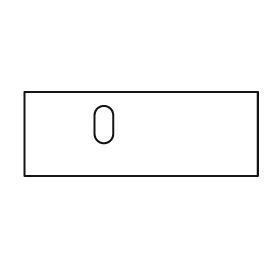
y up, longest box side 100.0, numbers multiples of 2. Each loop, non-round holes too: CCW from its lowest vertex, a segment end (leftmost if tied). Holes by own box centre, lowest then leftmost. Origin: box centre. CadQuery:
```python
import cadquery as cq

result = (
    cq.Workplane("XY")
    .moveTo(-50.0, -18.0)
    .lineTo(50.0, -18.0)
    .lineTo(50.0, 18.0)
    .lineTo(-50.0, 18.0)
    .close()
    .moveTo(-20.0, 0.0)
    .threePointArc((-16.0, -4.0), (-12.0, 0.0))
    .lineTo(-12.0, 8.0)
    .threePointArc((-16.0, 12.0), (-20.0, 8.0))
    .close()
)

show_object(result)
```